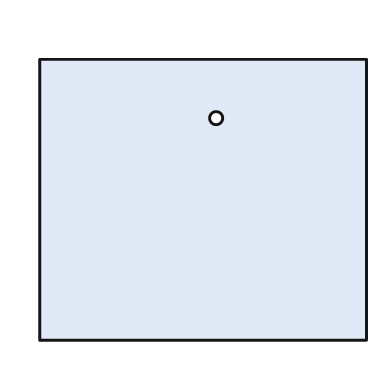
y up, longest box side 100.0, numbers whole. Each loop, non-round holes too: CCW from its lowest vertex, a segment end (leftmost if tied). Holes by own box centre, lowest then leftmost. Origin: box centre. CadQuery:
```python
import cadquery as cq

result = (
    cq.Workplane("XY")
    .moveTo(-50.0, -43.0)
    .lineTo(50.0, -43.0)
    .lineTo(50.0, 43.0)
    .lineTo(-50.0, 43.0)
    .close()
    .moveTo(4.0, 25.0)
    .circle(2.0)
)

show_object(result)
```